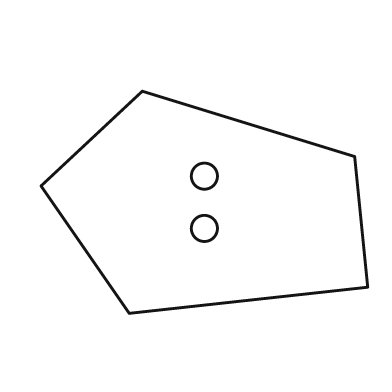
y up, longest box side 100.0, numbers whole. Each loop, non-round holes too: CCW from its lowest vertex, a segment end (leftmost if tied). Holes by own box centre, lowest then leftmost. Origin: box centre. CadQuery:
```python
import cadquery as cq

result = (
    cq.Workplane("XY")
    .moveTo(-23.0, -34.0)
    .lineTo(50.0, -26.0)
    .lineTo(46.0, 14.0)
    .lineTo(-19.0, 34.0)
    .lineTo(-50.0, 5.0)
    .close()
    .moveTo(0.0, -8.0)
    .circle(4.0)
    .moveTo(0.0, 8.0)
    .circle(4.0)
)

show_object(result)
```